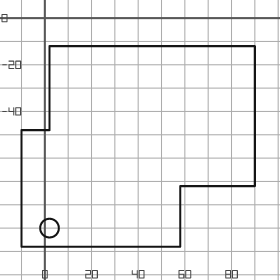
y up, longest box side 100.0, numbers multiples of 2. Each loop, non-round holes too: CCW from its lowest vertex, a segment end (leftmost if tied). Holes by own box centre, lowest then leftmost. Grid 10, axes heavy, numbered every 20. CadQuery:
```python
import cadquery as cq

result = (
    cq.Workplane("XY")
    .moveTo(-10.0, -98.0)
    .lineTo(58.0, -98.0)
    .lineTo(58.0, -72.0)
    .lineTo(90.0, -72.0)
    .lineTo(90.0, -12.0)
    .lineTo(2.0, -12.0)
    .lineTo(2.0, -48.0)
    .lineTo(-10.0, -48.0)
    .close()
    .moveTo(2.0, -90.0)
    .circle(4.0)
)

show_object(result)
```